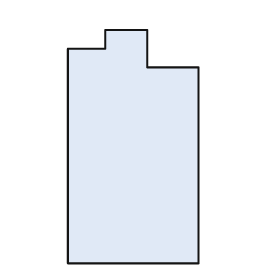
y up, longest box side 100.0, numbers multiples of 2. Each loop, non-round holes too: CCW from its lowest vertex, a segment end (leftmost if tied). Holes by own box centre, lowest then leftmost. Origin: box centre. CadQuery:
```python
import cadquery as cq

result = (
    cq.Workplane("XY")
    .moveTo(-28.0, -50.0)
    .lineTo(28.0, -50.0)
    .lineTo(28.0, 34.0)
    .lineTo(6.0, 34.0)
    .lineTo(6.0, 50.0)
    .lineTo(-12.0, 50.0)
    .lineTo(-12.0, 42.0)
    .lineTo(-28.0, 42.0)
    .close()
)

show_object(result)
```